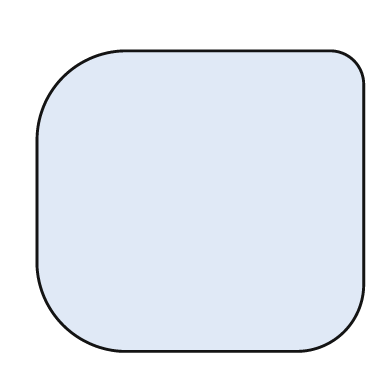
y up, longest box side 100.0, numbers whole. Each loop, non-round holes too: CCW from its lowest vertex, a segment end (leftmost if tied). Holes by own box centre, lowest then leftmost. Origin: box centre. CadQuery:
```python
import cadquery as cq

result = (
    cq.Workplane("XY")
    .moveTo(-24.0, -46.0)
    .lineTo(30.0, -46.0)
    .threePointArc((44.0, -40.0), (50.0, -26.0))
    .lineTo(50.0, 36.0)
    .threePointArc((47.0, 43.0), (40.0, 46.0))
    .lineTo(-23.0, 46.0)
    .threePointArc((-42.0, 38.0), (-50.0, 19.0))
    .lineTo(-50.0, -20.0)
    .threePointArc((-42.0, -38.0), (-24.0, -46.0))
    .close()
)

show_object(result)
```